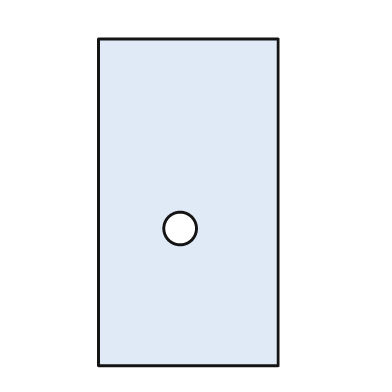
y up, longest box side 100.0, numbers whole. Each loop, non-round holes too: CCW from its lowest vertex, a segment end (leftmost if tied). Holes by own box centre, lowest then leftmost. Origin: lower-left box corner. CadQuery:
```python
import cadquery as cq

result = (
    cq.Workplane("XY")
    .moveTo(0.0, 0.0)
    .lineTo(55.0, 0.0)
    .lineTo(55.0, 100.0)
    .lineTo(0.0, 100.0)
    .close()
    .moveTo(25.0, 42.0)
    .circle(5.0)
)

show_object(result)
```